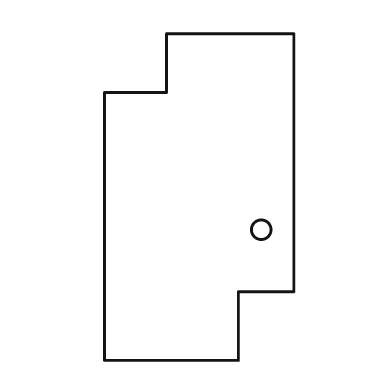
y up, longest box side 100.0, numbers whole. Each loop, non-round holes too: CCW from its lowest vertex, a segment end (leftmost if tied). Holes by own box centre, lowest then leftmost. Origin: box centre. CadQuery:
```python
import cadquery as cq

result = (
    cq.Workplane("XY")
    .moveTo(-29.0, -50.0)
    .lineTo(12.0, -50.0)
    .lineTo(12.0, -29.0)
    .lineTo(29.0, -29.0)
    .lineTo(29.0, 50.0)
    .lineTo(-10.0, 50.0)
    .lineTo(-10.0, 32.0)
    .lineTo(-29.0, 32.0)
    .close()
    .moveTo(19.0, -10.0)
    .circle(3.0)
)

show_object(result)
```